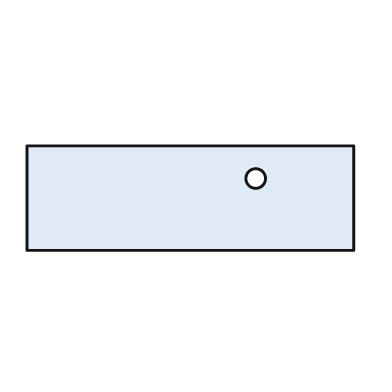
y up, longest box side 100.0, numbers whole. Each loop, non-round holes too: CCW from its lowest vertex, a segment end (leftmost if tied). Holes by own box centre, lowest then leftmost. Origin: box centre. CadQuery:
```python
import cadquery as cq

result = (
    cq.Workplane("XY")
    .moveTo(-50.0, -16.0)
    .lineTo(50.0, -16.0)
    .lineTo(50.0, 16.0)
    .lineTo(-50.0, 16.0)
    .close()
    .moveTo(20.0, 6.0)
    .circle(3.0)
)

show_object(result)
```